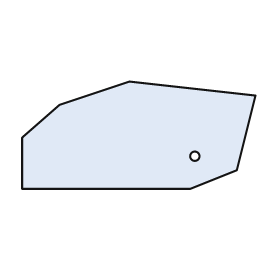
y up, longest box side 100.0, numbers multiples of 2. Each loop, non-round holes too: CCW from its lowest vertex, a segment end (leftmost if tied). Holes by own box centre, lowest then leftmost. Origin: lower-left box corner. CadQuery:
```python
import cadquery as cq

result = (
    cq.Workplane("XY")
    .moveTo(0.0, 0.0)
    .lineTo(72.0, 0.0)
    .lineTo(92.0, 8.0)
    .lineTo(100.0, 40.0)
    .lineTo(46.0, 46.0)
    .lineTo(16.0, 36.0)
    .lineTo(0.0, 22.0)
    .close()
    .moveTo(74.0, 14.0)
    .circle(2.0)
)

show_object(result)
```